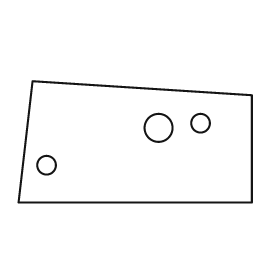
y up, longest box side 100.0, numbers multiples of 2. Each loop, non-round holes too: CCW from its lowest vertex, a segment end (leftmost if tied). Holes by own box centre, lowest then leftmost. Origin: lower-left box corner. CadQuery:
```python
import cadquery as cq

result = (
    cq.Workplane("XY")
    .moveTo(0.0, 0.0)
    .lineTo(100.0, 0.0)
    .lineTo(100.0, 46.0)
    .lineTo(6.0, 52.0)
    .close()
    .moveTo(12.0, 16.0)
    .circle(4.0)
    .moveTo(60.0, 32.0)
    .circle(6.0)
    .moveTo(78.0, 34.0)
    .circle(4.0)
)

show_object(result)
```